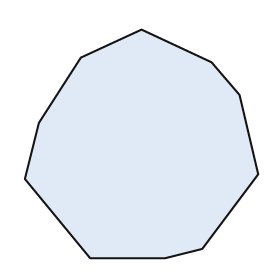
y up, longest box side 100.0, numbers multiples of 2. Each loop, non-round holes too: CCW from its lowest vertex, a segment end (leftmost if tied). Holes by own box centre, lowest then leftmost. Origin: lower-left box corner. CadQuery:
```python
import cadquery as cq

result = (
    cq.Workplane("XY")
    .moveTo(28.0, 0.0)
    .lineTo(60.0, 0.0)
    .lineTo(76.0, 4.0)
    .lineTo(100.0, 36.0)
    .lineTo(92.0, 70.0)
    .lineTo(80.0, 84.0)
    .lineTo(50.0, 98.0)
    .lineTo(24.0, 86.0)
    .lineTo(6.0, 58.0)
    .lineTo(0.0, 34.0)
    .close()
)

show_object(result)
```